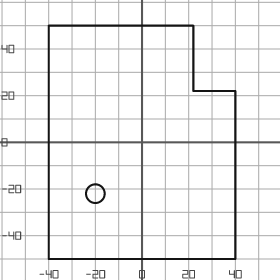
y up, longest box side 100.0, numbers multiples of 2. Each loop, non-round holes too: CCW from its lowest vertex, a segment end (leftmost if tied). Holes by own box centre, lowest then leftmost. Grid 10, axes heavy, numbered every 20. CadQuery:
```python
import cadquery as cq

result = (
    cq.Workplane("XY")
    .moveTo(-40.0, -50.0)
    .lineTo(40.0, -50.0)
    .lineTo(40.0, 22.0)
    .lineTo(22.0, 22.0)
    .lineTo(22.0, 50.0)
    .lineTo(-40.0, 50.0)
    .close()
    .moveTo(-20.0, -22.0)
    .circle(4.0)
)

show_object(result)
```